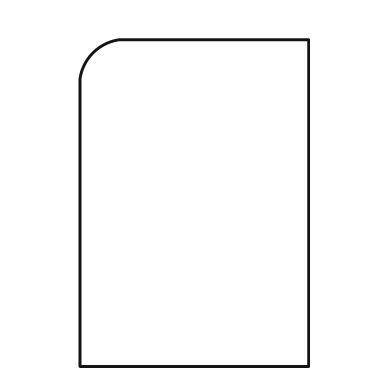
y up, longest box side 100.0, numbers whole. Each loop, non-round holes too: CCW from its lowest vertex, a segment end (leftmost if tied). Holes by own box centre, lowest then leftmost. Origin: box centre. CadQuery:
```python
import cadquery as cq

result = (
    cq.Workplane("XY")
    .moveTo(-35.0, -50.0)
    .lineTo(35.0, -50.0)
    .lineTo(35.0, 50.0)
    .lineTo(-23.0, 50.0)
    .threePointArc((-31.0, 46.0), (-35.0, 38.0))
    .close()
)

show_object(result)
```